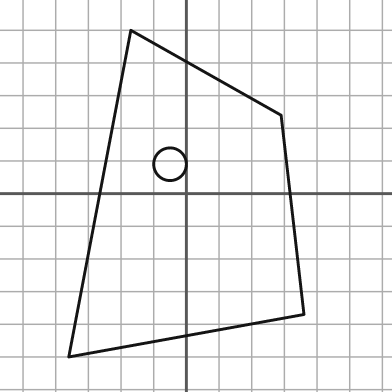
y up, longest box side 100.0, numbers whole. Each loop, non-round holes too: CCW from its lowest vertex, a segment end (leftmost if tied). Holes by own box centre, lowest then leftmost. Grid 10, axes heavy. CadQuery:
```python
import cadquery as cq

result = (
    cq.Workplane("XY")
    .moveTo(-36.0, -50.0)
    .lineTo(36.0, -37.0)
    .lineTo(29.0, 24.0)
    .lineTo(-17.0, 50.0)
    .close()
    .moveTo(-5.0, 9.0)
    .circle(5.0)
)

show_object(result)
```